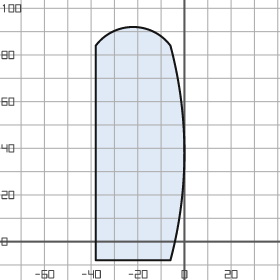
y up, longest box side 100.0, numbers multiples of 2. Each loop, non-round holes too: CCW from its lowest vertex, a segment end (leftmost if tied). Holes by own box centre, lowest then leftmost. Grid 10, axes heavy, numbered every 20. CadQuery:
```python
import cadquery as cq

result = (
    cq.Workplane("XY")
    .moveTo(-38.0, -8.0)
    .lineTo(-6.0, -8.0)
    .threePointArc((0.0, 38.0), (-6.0, 84.0))
    .threePointArc((-22.0, 92.0), (-38.0, 84.0))
    .close()
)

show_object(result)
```